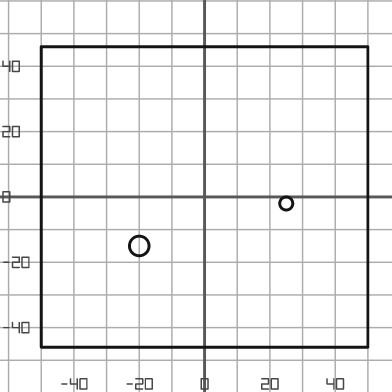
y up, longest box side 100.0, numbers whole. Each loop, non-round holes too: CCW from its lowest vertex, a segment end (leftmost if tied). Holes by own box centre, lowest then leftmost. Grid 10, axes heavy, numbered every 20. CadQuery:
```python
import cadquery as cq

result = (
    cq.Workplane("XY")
    .moveTo(-50.0, -46.0)
    .lineTo(50.0, -46.0)
    .lineTo(50.0, 46.0)
    .lineTo(-50.0, 46.0)
    .close()
    .moveTo(-20.0, -15.0)
    .circle(3.0)
    .moveTo(25.0, -2.0)
    .circle(2.0)
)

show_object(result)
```